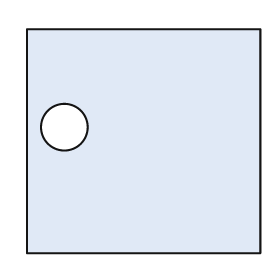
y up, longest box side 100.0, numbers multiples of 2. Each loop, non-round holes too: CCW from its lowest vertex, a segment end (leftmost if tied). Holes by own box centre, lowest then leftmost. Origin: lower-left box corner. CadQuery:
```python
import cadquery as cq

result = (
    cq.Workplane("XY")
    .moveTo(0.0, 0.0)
    .lineTo(100.0, 0.0)
    .lineTo(100.0, 96.0)
    .lineTo(0.0, 96.0)
    .close()
    .moveTo(16.0, 54.0)
    .circle(10.0)
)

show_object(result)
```